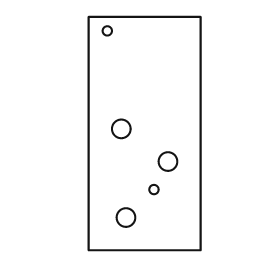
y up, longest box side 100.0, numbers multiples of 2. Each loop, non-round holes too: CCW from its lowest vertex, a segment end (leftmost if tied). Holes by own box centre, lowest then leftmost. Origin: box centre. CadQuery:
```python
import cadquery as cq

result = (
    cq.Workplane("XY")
    .moveTo(-24.0, -50.0)
    .lineTo(24.0, -50.0)
    .lineTo(24.0, 50.0)
    .lineTo(-24.0, 50.0)
    .close()
    .moveTo(-8.0, -36.0)
    .circle(4.0)
    .moveTo(4.0, -24.0)
    .circle(2.0)
    .moveTo(10.0, -12.0)
    .circle(4.0)
    .moveTo(-10.0, 2.0)
    .circle(4.0)
    .moveTo(-16.0, 44.0)
    .circle(2.0)
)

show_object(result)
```